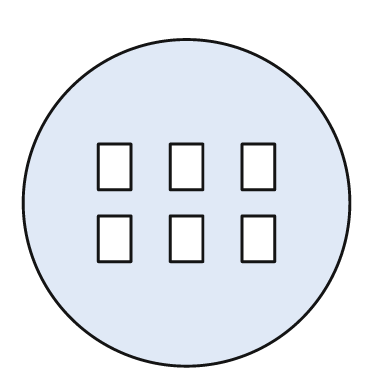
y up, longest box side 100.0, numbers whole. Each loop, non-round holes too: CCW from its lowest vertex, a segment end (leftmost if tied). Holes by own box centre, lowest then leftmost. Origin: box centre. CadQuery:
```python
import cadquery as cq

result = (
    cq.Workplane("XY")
    .moveTo(0.0, 0.0)
    .circle(50.0)
    .moveTo(-27.0, -18.0)
    .lineTo(-17.0, -18.0)
    .lineTo(-17.0, -4.0)
    .lineTo(-27.0, -4.0)
    .close()
    .moveTo(-5.0, -18.0)
    .lineTo(5.0, -18.0)
    .lineTo(5.0, -4.0)
    .lineTo(-5.0, -4.0)
    .close()
    .moveTo(17.0, -18.0)
    .lineTo(27.0, -18.0)
    .lineTo(27.0, -4.0)
    .lineTo(17.0, -4.0)
    .close()
    .moveTo(-27.0, 4.0)
    .lineTo(-17.0, 4.0)
    .lineTo(-17.0, 18.0)
    .lineTo(-27.0, 18.0)
    .close()
    .moveTo(-5.0, 4.0)
    .lineTo(5.0, 4.0)
    .lineTo(5.0, 18.0)
    .lineTo(-5.0, 18.0)
    .close()
    .moveTo(17.0, 4.0)
    .lineTo(27.0, 4.0)
    .lineTo(27.0, 18.0)
    .lineTo(17.0, 18.0)
    .close()
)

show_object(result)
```